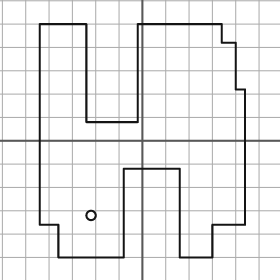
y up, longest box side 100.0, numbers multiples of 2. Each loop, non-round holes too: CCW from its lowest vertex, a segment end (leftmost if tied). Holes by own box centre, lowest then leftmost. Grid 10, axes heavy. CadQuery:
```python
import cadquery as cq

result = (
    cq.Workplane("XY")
    .moveTo(-36.0, -50.0)
    .lineTo(-8.0, -50.0)
    .lineTo(-8.0, -12.0)
    .lineTo(16.0, -12.0)
    .lineTo(16.0, -50.0)
    .lineTo(30.0, -50.0)
    .lineTo(30.0, -36.0)
    .lineTo(44.0, -36.0)
    .lineTo(44.0, 22.0)
    .lineTo(40.0, 22.0)
    .lineTo(40.0, 42.0)
    .lineTo(34.0, 42.0)
    .lineTo(34.0, 50.0)
    .lineTo(-2.0, 50.0)
    .lineTo(-2.0, 8.0)
    .lineTo(-24.0, 8.0)
    .lineTo(-24.0, 50.0)
    .lineTo(-44.0, 50.0)
    .lineTo(-44.0, -36.0)
    .lineTo(-36.0, -36.0)
    .close()
    .moveTo(-22.0, -32.0)
    .circle(2.0)
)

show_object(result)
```